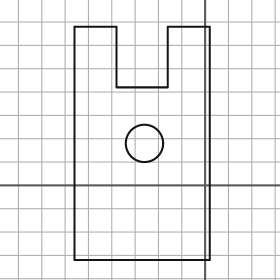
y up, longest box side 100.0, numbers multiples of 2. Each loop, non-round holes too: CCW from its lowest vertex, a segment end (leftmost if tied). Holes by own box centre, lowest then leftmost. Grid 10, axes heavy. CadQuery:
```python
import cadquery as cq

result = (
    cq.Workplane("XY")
    .moveTo(-56.0, -32.0)
    .lineTo(2.0, -32.0)
    .lineTo(2.0, 68.0)
    .lineTo(-16.0, 68.0)
    .lineTo(-16.0, 42.0)
    .lineTo(-38.0, 42.0)
    .lineTo(-38.0, 68.0)
    .lineTo(-56.0, 68.0)
    .close()
    .moveTo(-26.0, 18.0)
    .circle(8.0)
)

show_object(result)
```